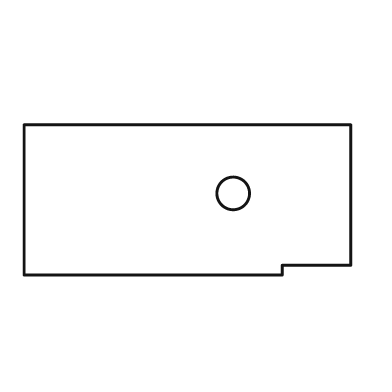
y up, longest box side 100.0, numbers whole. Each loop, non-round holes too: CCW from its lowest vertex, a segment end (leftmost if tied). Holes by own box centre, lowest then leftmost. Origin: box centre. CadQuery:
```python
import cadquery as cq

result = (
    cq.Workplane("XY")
    .moveTo(-50.0, -23.0)
    .lineTo(29.0, -23.0)
    .lineTo(29.0, -20.0)
    .lineTo(50.0, -20.0)
    .lineTo(50.0, 23.0)
    .lineTo(-50.0, 23.0)
    .close()
    .moveTo(14.0, 2.0)
    .circle(5.0)
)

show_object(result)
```